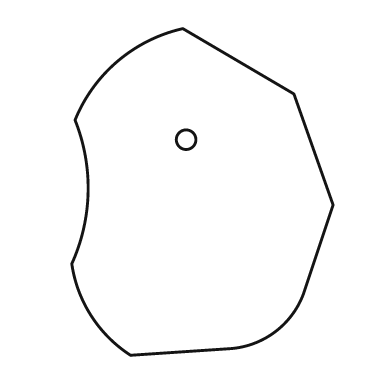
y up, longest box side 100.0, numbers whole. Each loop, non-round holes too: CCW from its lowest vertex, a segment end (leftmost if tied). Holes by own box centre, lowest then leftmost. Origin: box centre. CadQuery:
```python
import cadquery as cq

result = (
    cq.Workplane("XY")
    .moveTo(-22.0, -50.0)
    .lineTo(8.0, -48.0)
    .threePointArc((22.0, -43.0), (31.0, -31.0))
    .lineTo(40.0, -4.0)
    .lineTo(28.0, 30.0)
    .lineTo(-6.0, 50.0)
    .threePointArc((-26.0, 40.0), (-39.0, 22.0))
    .threePointArc((-35.0, 0.0), (-40.0, -22.0))
    .threePointArc((-34.0, -38.0), (-22.0, -50.0))
    .close()
    .moveTo(-5.0, 16.0)
    .circle(3.0)
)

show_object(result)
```